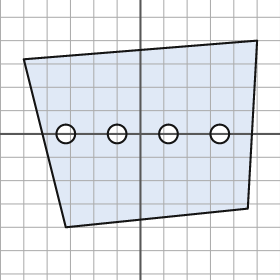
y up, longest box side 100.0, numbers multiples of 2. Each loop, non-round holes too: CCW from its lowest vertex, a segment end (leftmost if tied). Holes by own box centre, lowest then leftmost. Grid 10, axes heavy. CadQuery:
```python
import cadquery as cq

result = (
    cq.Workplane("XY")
    .moveTo(-32.0, -40.0)
    .lineTo(46.0, -32.0)
    .lineTo(50.0, 40.0)
    .lineTo(-50.0, 32.0)
    .close()
    .moveTo(-32.0, 0.0)
    .circle(4.0)
    .moveTo(-10.0, 0.0)
    .circle(4.0)
    .moveTo(12.0, 0.0)
    .circle(4.0)
    .moveTo(34.0, 0.0)
    .circle(4.0)
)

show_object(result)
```